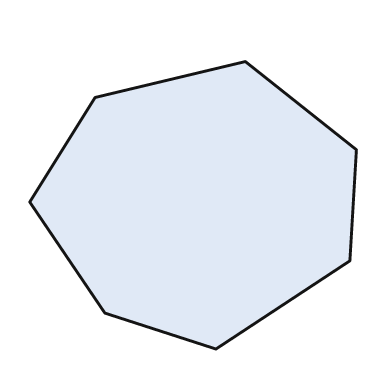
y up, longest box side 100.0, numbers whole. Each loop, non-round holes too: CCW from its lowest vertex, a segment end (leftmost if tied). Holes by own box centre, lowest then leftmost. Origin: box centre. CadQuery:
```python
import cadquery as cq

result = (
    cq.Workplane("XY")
    .moveTo(7.0, -44.0)
    .lineTo(48.0, -17.0)
    .lineTo(50.0, 17.0)
    .lineTo(16.0, 44.0)
    .lineTo(-30.0, 33.0)
    .lineTo(-50.0, 1.0)
    .lineTo(-27.0, -33.0)
    .close()
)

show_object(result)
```